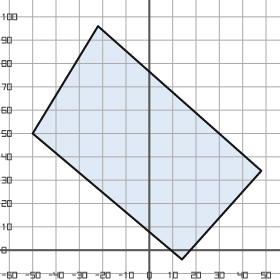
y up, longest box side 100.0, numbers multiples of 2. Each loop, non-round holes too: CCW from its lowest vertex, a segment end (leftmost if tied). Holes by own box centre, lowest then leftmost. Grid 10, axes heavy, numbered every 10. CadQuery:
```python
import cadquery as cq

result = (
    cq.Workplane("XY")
    .moveTo(14.0, -4.0)
    .lineTo(48.0, 34.0)
    .lineTo(-22.0, 96.0)
    .lineTo(-50.0, 50.0)
    .close()
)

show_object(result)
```